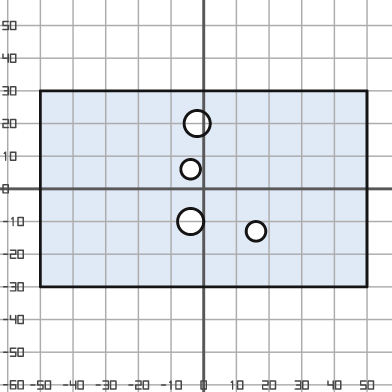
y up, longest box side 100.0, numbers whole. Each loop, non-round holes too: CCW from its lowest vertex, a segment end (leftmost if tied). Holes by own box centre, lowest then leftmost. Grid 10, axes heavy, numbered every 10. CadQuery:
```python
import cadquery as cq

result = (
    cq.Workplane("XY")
    .moveTo(-50.0, -30.0)
    .lineTo(50.0, -30.0)
    .lineTo(50.0, 30.0)
    .lineTo(-50.0, 30.0)
    .close()
    .moveTo(16.0, -13.0)
    .circle(3.0)
    .moveTo(-4.0, -10.0)
    .circle(4.0)
    .moveTo(-4.0, 6.0)
    .circle(3.0)
    .moveTo(-2.0, 20.0)
    .circle(4.0)
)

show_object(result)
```